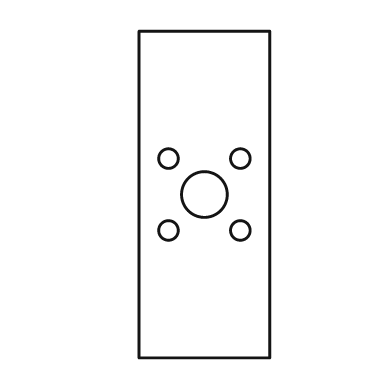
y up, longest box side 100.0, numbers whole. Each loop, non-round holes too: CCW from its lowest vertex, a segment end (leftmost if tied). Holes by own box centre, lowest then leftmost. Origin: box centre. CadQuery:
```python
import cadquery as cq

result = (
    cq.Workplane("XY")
    .moveTo(-20.0, -50.0)
    .lineTo(20.0, -50.0)
    .lineTo(20.0, 50.0)
    .lineTo(-20.0, 50.0)
    .close()
    .moveTo(-11.0, -11.0)
    .circle(3.0)
    .moveTo(11.0, -11.0)
    .circle(3.0)
    .moveTo(0.0, 0.0)
    .circle(7.0)
    .moveTo(-11.0, 11.0)
    .circle(3.0)
    .moveTo(11.0, 11.0)
    .circle(3.0)
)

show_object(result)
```